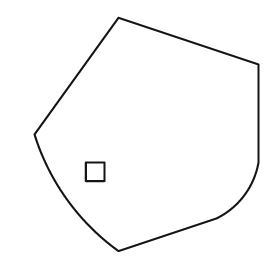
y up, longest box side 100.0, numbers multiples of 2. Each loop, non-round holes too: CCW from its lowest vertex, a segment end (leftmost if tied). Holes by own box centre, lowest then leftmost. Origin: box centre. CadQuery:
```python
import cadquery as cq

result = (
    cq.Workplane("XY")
    .moveTo(-12.0, -50.0)
    .lineTo(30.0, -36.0)
    .threePointArc((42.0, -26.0), (48.0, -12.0))
    .lineTo(48.0, 30.0)
    .lineTo(-12.0, 50.0)
    .lineTo(-48.0, 0.0)
    .threePointArc((-34.0, -28.0), (-12.0, -50.0))
    .close()
    .moveTo(-26.0, -20.0)
    .lineTo(-18.0, -20.0)
    .lineTo(-18.0, -12.0)
    .lineTo(-26.0, -12.0)
    .close()
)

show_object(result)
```